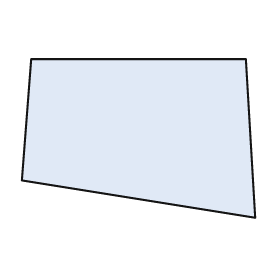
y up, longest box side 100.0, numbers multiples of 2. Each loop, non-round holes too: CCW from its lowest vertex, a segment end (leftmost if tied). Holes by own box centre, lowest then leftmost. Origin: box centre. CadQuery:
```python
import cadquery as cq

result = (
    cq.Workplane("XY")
    .moveTo(50.0, -34.0)
    .lineTo(46.0, 34.0)
    .lineTo(-46.0, 34.0)
    .lineTo(-50.0, -18.0)
    .close()
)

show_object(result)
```